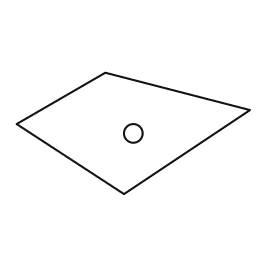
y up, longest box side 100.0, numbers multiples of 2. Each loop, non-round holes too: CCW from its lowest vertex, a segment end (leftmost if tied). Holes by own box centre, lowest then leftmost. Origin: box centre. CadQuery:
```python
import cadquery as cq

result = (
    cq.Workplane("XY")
    .moveTo(-4.0, -26.0)
    .lineTo(50.0, 10.0)
    .lineTo(-12.0, 26.0)
    .lineTo(-50.0, 4.0)
    .close()
    .moveTo(0.0, 0.0)
    .circle(4.0)
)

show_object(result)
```